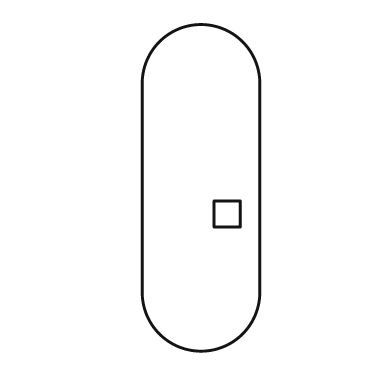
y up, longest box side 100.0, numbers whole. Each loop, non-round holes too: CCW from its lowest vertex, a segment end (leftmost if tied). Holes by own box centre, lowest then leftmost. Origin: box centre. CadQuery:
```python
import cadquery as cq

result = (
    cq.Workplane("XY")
    .moveTo(-18.0, -32.0)
    .threePointArc((0.0, -50.0), (18.0, -32.0))
    .lineTo(18.0, 32.0)
    .threePointArc((0.0, 50.0), (-18.0, 32.0))
    .close()
    .moveTo(4.0, -12.0)
    .lineTo(12.0, -12.0)
    .lineTo(12.0, -4.0)
    .lineTo(4.0, -4.0)
    .close()
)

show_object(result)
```